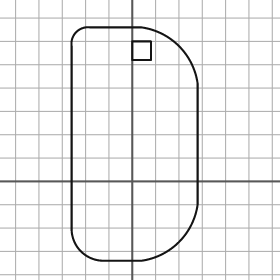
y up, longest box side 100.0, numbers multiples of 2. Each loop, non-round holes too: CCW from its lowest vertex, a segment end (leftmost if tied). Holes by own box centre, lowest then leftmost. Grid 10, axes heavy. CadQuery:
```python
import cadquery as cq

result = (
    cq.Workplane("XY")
    .moveTo(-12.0, -34.0)
    .lineTo(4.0, -34.0)
    .threePointArc((20.0, -26.0), (28.0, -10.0))
    .lineTo(28.0, 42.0)
    .threePointArc((20.0, 58.0), (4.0, 66.0))
    .lineTo(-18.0, 66.0)
    .threePointArc((-24.0, 64.0), (-26.0, 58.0))
    .lineTo(-26.0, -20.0)
    .threePointArc((-22.0, -30.0), (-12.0, -34.0))
    .close()
    .moveTo(0.0, 52.0)
    .lineTo(8.0, 52.0)
    .lineTo(8.0, 60.0)
    .lineTo(0.0, 60.0)
    .close()
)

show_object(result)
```